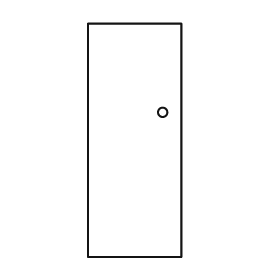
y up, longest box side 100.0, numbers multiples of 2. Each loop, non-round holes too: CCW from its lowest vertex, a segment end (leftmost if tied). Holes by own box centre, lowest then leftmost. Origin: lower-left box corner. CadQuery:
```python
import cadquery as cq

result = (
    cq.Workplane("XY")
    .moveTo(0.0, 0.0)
    .lineTo(40.0, 0.0)
    .lineTo(40.0, 100.0)
    .lineTo(0.0, 100.0)
    .close()
    .moveTo(32.0, 62.0)
    .circle(2.0)
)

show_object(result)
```